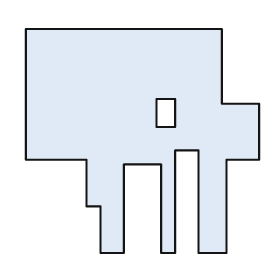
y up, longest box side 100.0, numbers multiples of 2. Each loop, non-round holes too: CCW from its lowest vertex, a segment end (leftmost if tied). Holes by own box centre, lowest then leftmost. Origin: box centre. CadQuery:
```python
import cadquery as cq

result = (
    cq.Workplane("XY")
    .moveTo(-18.0, -48.0)
    .lineTo(-8.0, -48.0)
    .lineTo(-8.0, -10.0)
    .lineTo(8.0, -10.0)
    .lineTo(8.0, -48.0)
    .lineTo(14.0, -48.0)
    .lineTo(14.0, -4.0)
    .lineTo(24.0, -4.0)
    .lineTo(24.0, -48.0)
    .lineTo(36.0, -48.0)
    .lineTo(36.0, -8.0)
    .lineTo(50.0, -8.0)
    .lineTo(50.0, 16.0)
    .lineTo(34.0, 16.0)
    .lineTo(34.0, 48.0)
    .lineTo(-50.0, 48.0)
    .lineTo(-50.0, -8.0)
    .lineTo(-24.0, -8.0)
    .lineTo(-24.0, -28.0)
    .lineTo(-18.0, -28.0)
    .close()
    .moveTo(6.0, 6.0)
    .lineTo(14.0, 6.0)
    .lineTo(14.0, 18.0)
    .lineTo(6.0, 18.0)
    .close()
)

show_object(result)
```